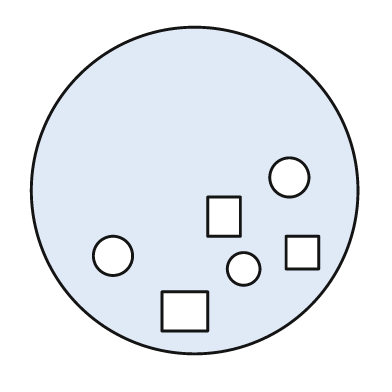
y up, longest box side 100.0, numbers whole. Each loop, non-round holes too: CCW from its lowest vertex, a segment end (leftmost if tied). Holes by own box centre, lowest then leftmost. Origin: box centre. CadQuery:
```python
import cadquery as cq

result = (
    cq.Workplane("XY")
    .moveTo(0.0, 0.0)
    .circle(50.0)
    .moveTo(-10.0, -43.0)
    .lineTo(4.0, -43.0)
    .lineTo(4.0, -31.0)
    .lineTo(-10.0, -31.0)
    .close()
    .moveTo(15.0, -24.0)
    .circle(5.0)
    .moveTo(-25.0, -20.0)
    .circle(6.0)
    .moveTo(28.0, -24.0)
    .lineTo(38.0, -24.0)
    .lineTo(38.0, -14.0)
    .lineTo(28.0, -14.0)
    .close()
    .moveTo(4.0, -14.0)
    .lineTo(14.0, -14.0)
    .lineTo(14.0, -2.0)
    .lineTo(4.0, -2.0)
    .close()
    .moveTo(29.0, 4.0)
    .circle(6.0)
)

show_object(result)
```